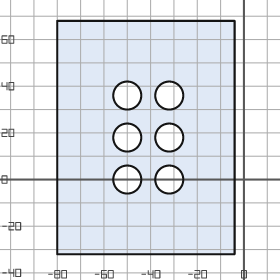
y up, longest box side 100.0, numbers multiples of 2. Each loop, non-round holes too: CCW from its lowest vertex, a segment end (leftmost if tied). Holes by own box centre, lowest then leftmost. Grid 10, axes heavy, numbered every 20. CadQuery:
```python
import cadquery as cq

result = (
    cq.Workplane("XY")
    .moveTo(-80.0, -32.0)
    .lineTo(-4.0, -32.0)
    .lineTo(-4.0, 68.0)
    .lineTo(-80.0, 68.0)
    .close()
    .moveTo(-50.0, 0.0)
    .circle(6.0)
    .moveTo(-32.0, 0.0)
    .circle(6.0)
    .moveTo(-50.0, 18.0)
    .circle(6.0)
    .moveTo(-32.0, 18.0)
    .circle(6.0)
    .moveTo(-50.0, 36.0)
    .circle(6.0)
    .moveTo(-32.0, 36.0)
    .circle(6.0)
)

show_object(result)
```